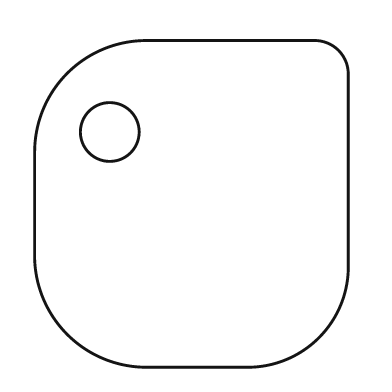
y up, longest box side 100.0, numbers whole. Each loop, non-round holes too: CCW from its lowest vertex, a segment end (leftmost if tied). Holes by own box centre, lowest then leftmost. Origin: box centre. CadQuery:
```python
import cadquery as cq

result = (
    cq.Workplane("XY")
    .moveTo(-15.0, -50.0)
    .lineTo(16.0, -50.0)
    .threePointArc((39.0, -41.0), (48.0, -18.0))
    .lineTo(48.0, 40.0)
    .threePointArc((45.0, 47.0), (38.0, 50.0))
    .lineTo(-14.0, 50.0)
    .threePointArc((-38.0, 40.0), (-48.0, 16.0))
    .lineTo(-48.0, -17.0)
    .threePointArc((-38.0, -40.0), (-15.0, -50.0))
    .close()
    .moveTo(-25.0, 22.0)
    .circle(9.0)
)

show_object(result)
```